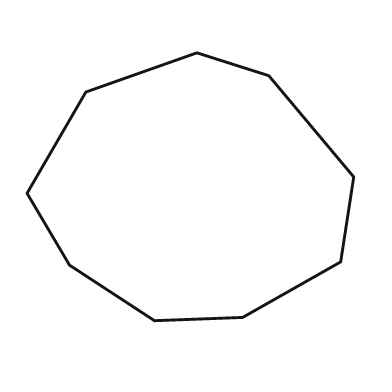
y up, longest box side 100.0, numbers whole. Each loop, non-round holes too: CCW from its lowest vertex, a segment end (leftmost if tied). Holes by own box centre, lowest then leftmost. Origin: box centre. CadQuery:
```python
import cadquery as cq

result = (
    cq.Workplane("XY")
    .moveTo(-11.0, -41.0)
    .lineTo(16.0, -40.0)
    .lineTo(46.0, -23.0)
    .lineTo(50.0, 3.0)
    .lineTo(24.0, 34.0)
    .lineTo(2.0, 41.0)
    .lineTo(-32.0, 29.0)
    .lineTo(-50.0, -2.0)
    .lineTo(-37.0, -24.0)
    .close()
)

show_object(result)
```